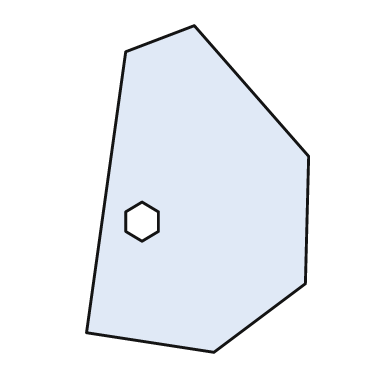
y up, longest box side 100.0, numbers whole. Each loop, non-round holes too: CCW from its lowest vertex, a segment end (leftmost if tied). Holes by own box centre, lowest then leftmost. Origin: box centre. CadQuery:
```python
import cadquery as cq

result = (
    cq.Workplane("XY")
    .moveTo(5.0, -50.0)
    .lineTo(33.0, -29.0)
    .lineTo(34.0, 10.0)
    .lineTo(-1.0, 50.0)
    .lineTo(-22.0, 42.0)
    .lineTo(-34.0, -44.0)
    .close()
    .moveTo(-17.0, -16.0)
    .lineTo(-12.0, -13.0)
    .lineTo(-12.0, -7.0)
    .lineTo(-17.0, -4.0)
    .lineTo(-22.0, -7.0)
    .lineTo(-22.0, -13.0)
    .close()
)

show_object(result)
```